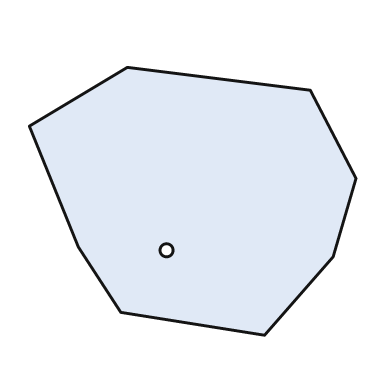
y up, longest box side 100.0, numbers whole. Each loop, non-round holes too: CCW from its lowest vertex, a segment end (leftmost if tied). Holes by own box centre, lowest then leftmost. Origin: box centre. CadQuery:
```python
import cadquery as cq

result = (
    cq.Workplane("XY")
    .moveTo(22.0, -41.0)
    .lineTo(43.0, -17.0)
    .lineTo(50.0, 7.0)
    .lineTo(36.0, 34.0)
    .lineTo(-20.0, 41.0)
    .lineTo(-50.0, 23.0)
    .lineTo(-35.0, -14.0)
    .lineTo(-22.0, -34.0)
    .close()
    .moveTo(-8.0, -15.0)
    .circle(2.0)
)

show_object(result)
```